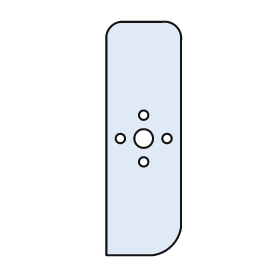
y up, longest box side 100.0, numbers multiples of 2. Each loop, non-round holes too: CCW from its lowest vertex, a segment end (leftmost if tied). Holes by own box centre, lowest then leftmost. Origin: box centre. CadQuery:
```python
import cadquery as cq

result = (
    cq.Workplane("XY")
    .moveTo(-16.0, -50.0)
    .lineTo(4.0, -50.0)
    .threePointArc((12.0, -46.0), (16.0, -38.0))
    .lineTo(16.0, 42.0)
    .threePointArc((14.0, 48.0), (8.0, 50.0))
    .lineTo(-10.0, 50.0)
    .threePointArc((-14.0, 48.0), (-16.0, 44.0))
    .close()
    .moveTo(0.0, -10.0)
    .circle(2.0)
    .moveTo(-10.0, 0.0)
    .circle(2.0)
    .moveTo(0.0, 0.0)
    .circle(4.0)
    .moveTo(10.0, 0.0)
    .circle(2.0)
    .moveTo(0.0, 10.0)
    .circle(2.0)
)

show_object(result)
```